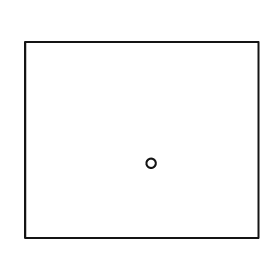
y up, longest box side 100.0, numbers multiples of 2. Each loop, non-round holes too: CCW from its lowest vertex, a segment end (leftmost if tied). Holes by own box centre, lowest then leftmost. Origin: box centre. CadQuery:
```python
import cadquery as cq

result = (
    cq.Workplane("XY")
    .moveTo(-50.0, -42.0)
    .lineTo(50.0, -42.0)
    .lineTo(50.0, 42.0)
    .lineTo(-50.0, 42.0)
    .close()
    .moveTo(4.0, -10.0)
    .circle(2.0)
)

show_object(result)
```